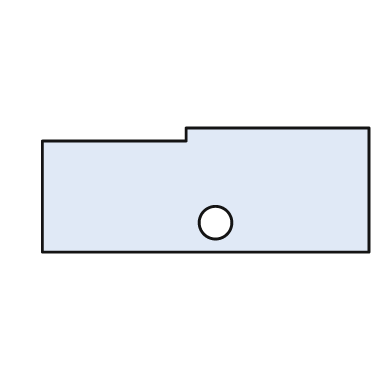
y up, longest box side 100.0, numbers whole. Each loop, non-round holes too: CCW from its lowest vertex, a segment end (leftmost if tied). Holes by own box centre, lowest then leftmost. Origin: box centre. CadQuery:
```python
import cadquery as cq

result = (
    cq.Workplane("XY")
    .moveTo(-50.0, -19.0)
    .lineTo(50.0, -19.0)
    .lineTo(50.0, 19.0)
    .lineTo(-6.0, 19.0)
    .lineTo(-6.0, 15.0)
    .lineTo(-50.0, 15.0)
    .close()
    .moveTo(3.0, -10.0)
    .circle(5.0)
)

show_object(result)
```